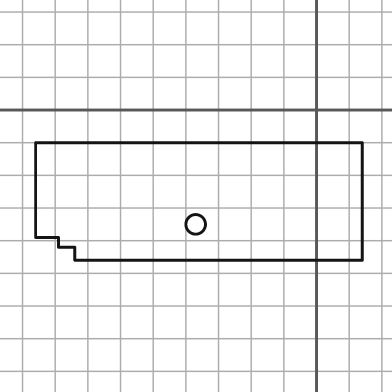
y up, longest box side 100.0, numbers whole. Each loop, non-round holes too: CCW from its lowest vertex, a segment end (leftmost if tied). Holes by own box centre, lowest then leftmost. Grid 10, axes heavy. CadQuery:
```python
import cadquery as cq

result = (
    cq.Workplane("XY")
    .moveTo(-74.0, -46.0)
    .lineTo(14.0, -46.0)
    .lineTo(14.0, -10.0)
    .lineTo(-86.0, -10.0)
    .lineTo(-86.0, -39.0)
    .lineTo(-79.0, -39.0)
    .lineTo(-79.0, -42.0)
    .lineTo(-74.0, -42.0)
    .close()
    .moveTo(-37.0, -35.0)
    .circle(3.0)
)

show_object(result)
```